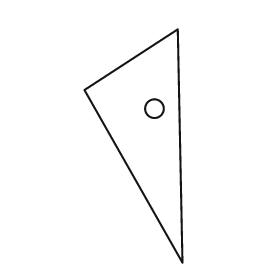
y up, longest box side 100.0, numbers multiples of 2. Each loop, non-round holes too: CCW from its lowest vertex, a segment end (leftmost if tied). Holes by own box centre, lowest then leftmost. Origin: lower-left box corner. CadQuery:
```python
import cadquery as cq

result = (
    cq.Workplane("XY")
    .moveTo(42.0, 0.0)
    .lineTo(40.0, 100.0)
    .lineTo(0.0, 74.0)
    .close()
    .moveTo(30.0, 66.0)
    .circle(4.0)
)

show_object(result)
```